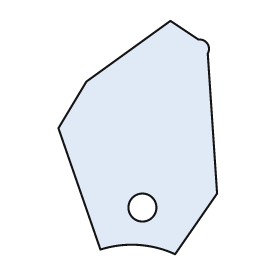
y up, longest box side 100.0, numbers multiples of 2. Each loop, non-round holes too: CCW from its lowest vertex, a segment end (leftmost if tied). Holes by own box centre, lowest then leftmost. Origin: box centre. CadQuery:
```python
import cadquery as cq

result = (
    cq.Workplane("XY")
    .moveTo(16.0, -50.0)
    .lineTo(34.0, -24.0)
    .lineTo(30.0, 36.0)
    .threePointArc((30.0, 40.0), (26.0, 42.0))
    .lineTo(14.0, 50.0)
    .lineTo(-22.0, 24.0)
    .lineTo(-34.0, 4.0)
    .lineTo(-16.0, -48.0)
    .threePointArc((0.0, -46.0), (16.0, -50.0))
    .close()
    .moveTo(2.0, -30.0)
    .circle(6.0)
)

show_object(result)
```